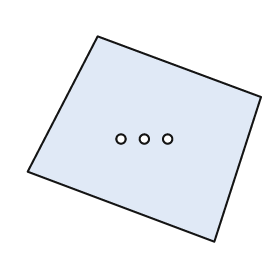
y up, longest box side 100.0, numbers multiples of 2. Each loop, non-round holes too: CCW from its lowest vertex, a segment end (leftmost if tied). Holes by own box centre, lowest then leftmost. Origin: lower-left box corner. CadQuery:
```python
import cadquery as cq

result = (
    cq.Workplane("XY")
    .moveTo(80.0, 0.0)
    .lineTo(100.0, 62.0)
    .lineTo(30.0, 88.0)
    .lineTo(0.0, 30.0)
    .close()
    .moveTo(40.0, 44.0)
    .circle(2.0)
    .moveTo(50.0, 44.0)
    .circle(2.0)
    .moveTo(60.0, 44.0)
    .circle(2.0)
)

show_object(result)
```